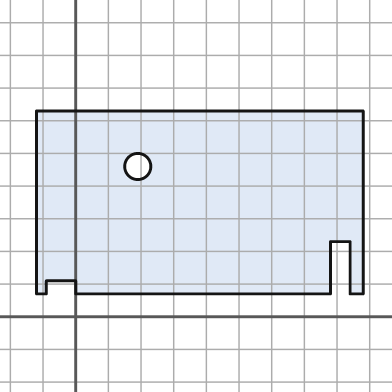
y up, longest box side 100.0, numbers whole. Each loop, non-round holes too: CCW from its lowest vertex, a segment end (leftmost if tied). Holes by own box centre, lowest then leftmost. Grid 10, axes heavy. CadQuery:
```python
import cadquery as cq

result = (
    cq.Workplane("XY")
    .moveTo(-12.0, 7.0)
    .lineTo(-9.0, 7.0)
    .lineTo(-9.0, 11.0)
    .lineTo(0.0, 11.0)
    .lineTo(0.0, 7.0)
    .lineTo(78.0, 7.0)
    .lineTo(78.0, 23.0)
    .lineTo(84.0, 23.0)
    .lineTo(84.0, 7.0)
    .lineTo(88.0, 7.0)
    .lineTo(88.0, 63.0)
    .lineTo(-12.0, 63.0)
    .close()
    .moveTo(19.0, 46.0)
    .circle(4.0)
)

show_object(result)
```